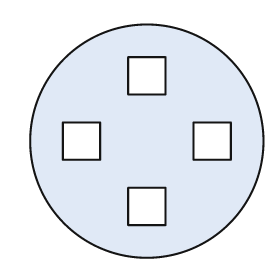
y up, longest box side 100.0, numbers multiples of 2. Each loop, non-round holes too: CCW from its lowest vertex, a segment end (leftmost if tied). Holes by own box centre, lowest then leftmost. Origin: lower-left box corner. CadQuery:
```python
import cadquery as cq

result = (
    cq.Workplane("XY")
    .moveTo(50.0, 50.0)
    .circle(50.0)
    .moveTo(42.0, 14.0)
    .lineTo(58.0, 14.0)
    .lineTo(58.0, 30.0)
    .lineTo(42.0, 30.0)
    .close()
    .moveTo(14.0, 42.0)
    .lineTo(30.0, 42.0)
    .lineTo(30.0, 58.0)
    .lineTo(14.0, 58.0)
    .close()
    .moveTo(70.0, 42.0)
    .lineTo(86.0, 42.0)
    .lineTo(86.0, 58.0)
    .lineTo(70.0, 58.0)
    .close()
    .moveTo(42.0, 70.0)
    .lineTo(58.0, 70.0)
    .lineTo(58.0, 86.0)
    .lineTo(42.0, 86.0)
    .close()
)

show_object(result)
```